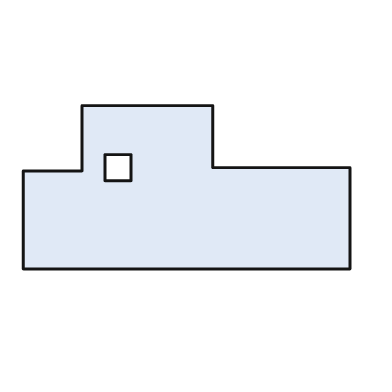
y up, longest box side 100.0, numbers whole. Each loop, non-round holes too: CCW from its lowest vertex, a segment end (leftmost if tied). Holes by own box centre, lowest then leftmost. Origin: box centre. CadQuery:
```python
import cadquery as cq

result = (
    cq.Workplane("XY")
    .moveTo(-50.0, -25.0)
    .lineTo(50.0, -25.0)
    .lineTo(50.0, 6.0)
    .lineTo(8.0, 6.0)
    .lineTo(8.0, 25.0)
    .lineTo(-32.0, 25.0)
    .lineTo(-32.0, 5.0)
    .lineTo(-50.0, 5.0)
    .close()
    .moveTo(-25.0, 2.0)
    .lineTo(-17.0, 2.0)
    .lineTo(-17.0, 10.0)
    .lineTo(-25.0, 10.0)
    .close()
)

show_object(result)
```